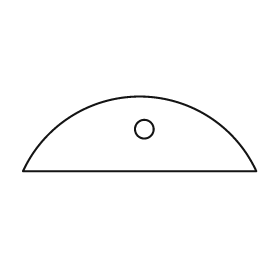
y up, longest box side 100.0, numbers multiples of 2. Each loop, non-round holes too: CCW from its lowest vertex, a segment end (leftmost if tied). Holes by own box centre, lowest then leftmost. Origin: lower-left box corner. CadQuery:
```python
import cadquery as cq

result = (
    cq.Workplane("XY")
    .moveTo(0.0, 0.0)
    .lineTo(100.0, 0.0)
    .threePointArc((50.0, 32.0), (0.0, 0.0))
    .close()
    .moveTo(52.0, 18.0)
    .circle(4.0)
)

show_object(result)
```